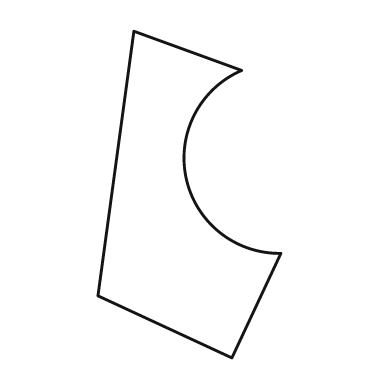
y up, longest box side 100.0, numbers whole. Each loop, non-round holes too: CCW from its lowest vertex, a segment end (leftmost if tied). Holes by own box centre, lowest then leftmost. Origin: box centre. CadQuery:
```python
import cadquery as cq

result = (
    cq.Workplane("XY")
    .moveTo(13.0, -50.0)
    .lineTo(28.0, -18.0)
    .threePointArc((-1.0, 5.0), (16.0, 38.0))
    .lineTo(-17.0, 50.0)
    .lineTo(-28.0, -31.0)
    .close()
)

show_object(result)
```